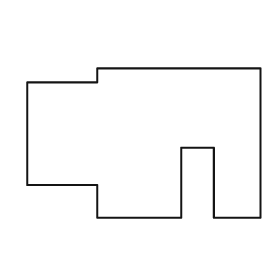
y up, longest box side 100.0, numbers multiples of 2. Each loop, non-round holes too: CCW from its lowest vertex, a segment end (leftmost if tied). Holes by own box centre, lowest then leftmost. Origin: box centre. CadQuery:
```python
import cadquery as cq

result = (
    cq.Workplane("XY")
    .moveTo(-20.0, -32.0)
    .lineTo(16.0, -32.0)
    .lineTo(16.0, -2.0)
    .lineTo(30.0, -2.0)
    .lineTo(30.0, -32.0)
    .lineTo(50.0, -32.0)
    .lineTo(50.0, 32.0)
    .lineTo(-20.0, 32.0)
    .lineTo(-20.0, 26.0)
    .lineTo(-50.0, 26.0)
    .lineTo(-50.0, -18.0)
    .lineTo(-20.0, -18.0)
    .close()
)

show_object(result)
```